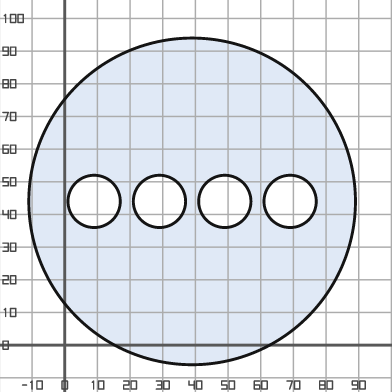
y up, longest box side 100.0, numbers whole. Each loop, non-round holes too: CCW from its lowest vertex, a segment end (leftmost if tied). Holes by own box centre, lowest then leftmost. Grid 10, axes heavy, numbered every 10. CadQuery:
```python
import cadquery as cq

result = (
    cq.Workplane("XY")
    .moveTo(39.0, 44.0)
    .circle(50.0)
    .moveTo(9.0, 44.0)
    .circle(8.0)
    .moveTo(29.0, 44.0)
    .circle(8.0)
    .moveTo(49.0, 44.0)
    .circle(8.0)
    .moveTo(69.0, 44.0)
    .circle(8.0)
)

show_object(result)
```